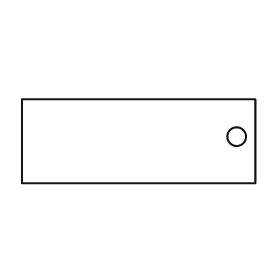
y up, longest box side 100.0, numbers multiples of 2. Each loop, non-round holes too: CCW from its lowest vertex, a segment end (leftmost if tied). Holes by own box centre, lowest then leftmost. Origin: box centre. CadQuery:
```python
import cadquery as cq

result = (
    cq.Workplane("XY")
    .moveTo(-50.0, -18.0)
    .lineTo(50.0, -18.0)
    .lineTo(50.0, 18.0)
    .lineTo(-50.0, 18.0)
    .close()
    .moveTo(42.0, 2.0)
    .circle(4.0)
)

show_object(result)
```